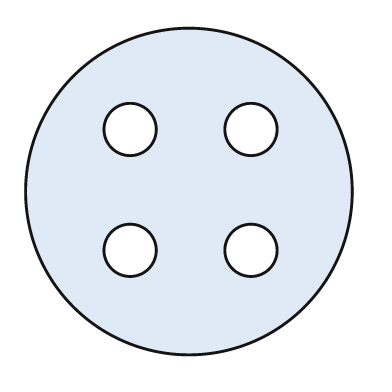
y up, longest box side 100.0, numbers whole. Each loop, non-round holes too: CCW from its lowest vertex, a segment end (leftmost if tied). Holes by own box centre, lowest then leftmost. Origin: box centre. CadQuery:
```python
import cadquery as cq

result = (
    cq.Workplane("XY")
    .moveTo(0.0, 0.0)
    .circle(50.0)
    .moveTo(-18.0, -18.0)
    .circle(8.0)
    .moveTo(19.0, -18.0)
    .circle(8.0)
    .moveTo(-18.0, 19.0)
    .circle(8.0)
    .moveTo(19.0, 19.0)
    .circle(8.0)
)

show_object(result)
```